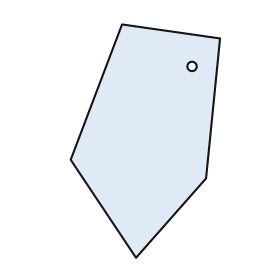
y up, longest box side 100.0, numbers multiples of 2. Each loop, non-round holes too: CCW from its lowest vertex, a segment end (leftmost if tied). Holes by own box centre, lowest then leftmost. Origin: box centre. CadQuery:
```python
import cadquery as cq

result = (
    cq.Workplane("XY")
    .moveTo(-4.0, -50.0)
    .lineTo(26.0, -16.0)
    .lineTo(32.0, 44.0)
    .lineTo(-10.0, 50.0)
    .lineTo(-32.0, -8.0)
    .close()
    .moveTo(20.0, 32.0)
    .circle(2.0)
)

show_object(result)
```